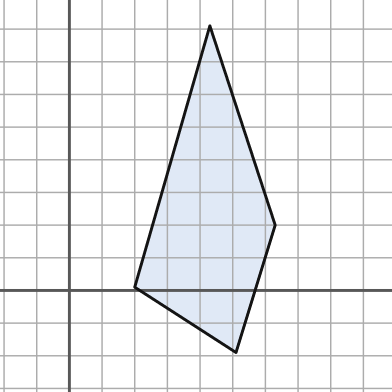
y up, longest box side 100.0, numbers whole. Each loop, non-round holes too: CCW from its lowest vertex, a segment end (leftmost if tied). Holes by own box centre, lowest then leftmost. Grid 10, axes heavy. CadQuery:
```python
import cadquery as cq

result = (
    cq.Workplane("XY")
    .moveTo(51.0, -19.0)
    .lineTo(63.0, 20.0)
    .lineTo(43.0, 81.0)
    .lineTo(20.0, 1.0)
    .close()
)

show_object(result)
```